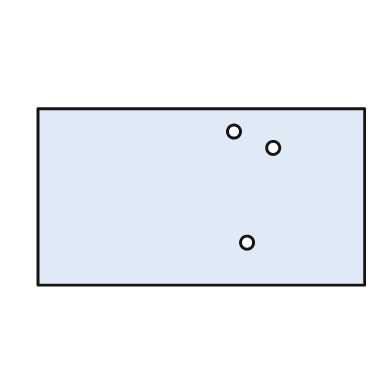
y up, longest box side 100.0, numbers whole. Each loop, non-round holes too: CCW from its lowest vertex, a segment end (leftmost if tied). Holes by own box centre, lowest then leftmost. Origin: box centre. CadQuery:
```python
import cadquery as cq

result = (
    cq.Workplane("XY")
    .moveTo(-50.0, -27.0)
    .lineTo(50.0, -27.0)
    .lineTo(50.0, 27.0)
    .lineTo(-50.0, 27.0)
    .close()
    .moveTo(14.0, -14.0)
    .circle(2.0)
    .moveTo(22.0, 15.0)
    .circle(2.0)
    .moveTo(10.0, 20.0)
    .circle(2.0)
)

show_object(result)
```